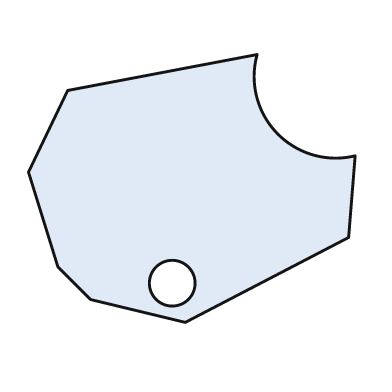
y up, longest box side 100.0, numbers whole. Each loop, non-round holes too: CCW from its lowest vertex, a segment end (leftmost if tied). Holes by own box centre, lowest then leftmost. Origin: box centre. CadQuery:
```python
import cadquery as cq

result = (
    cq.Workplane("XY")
    .moveTo(-2.0, -41.0)
    .lineTo(48.0, -15.0)
    .lineTo(50.0, 10.0)
    .threePointArc((26.0, 17.0), (20.0, 41.0))
    .lineTo(-38.0, 30.0)
    .lineTo(-50.0, 5.0)
    .lineTo(-41.0, -24.0)
    .lineTo(-31.0, -34.0)
    .close()
    .moveTo(-6.0, -29.0)
    .circle(7.0)
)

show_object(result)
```